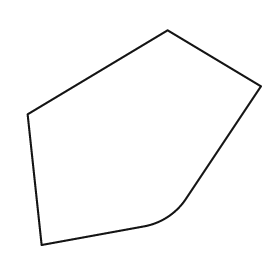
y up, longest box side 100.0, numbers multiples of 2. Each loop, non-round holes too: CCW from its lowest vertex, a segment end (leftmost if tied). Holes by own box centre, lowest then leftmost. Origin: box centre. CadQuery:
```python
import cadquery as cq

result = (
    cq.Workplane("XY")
    .moveTo(-44.0, -46.0)
    .lineTo(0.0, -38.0)
    .threePointArc((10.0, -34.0), (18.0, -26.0))
    .lineTo(50.0, 22.0)
    .lineTo(10.0, 46.0)
    .lineTo(-50.0, 10.0)
    .close()
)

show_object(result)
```